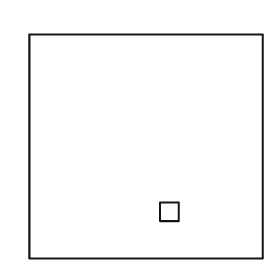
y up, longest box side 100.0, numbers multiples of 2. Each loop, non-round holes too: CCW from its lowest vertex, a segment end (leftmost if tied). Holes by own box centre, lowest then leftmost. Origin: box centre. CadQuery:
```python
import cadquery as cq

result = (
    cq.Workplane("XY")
    .moveTo(-50.0, -48.0)
    .lineTo(50.0, -48.0)
    .lineTo(50.0, 48.0)
    .lineTo(-50.0, 48.0)
    .close()
    .moveTo(6.0, -32.0)
    .lineTo(14.0, -32.0)
    .lineTo(14.0, -24.0)
    .lineTo(6.0, -24.0)
    .close()
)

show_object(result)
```